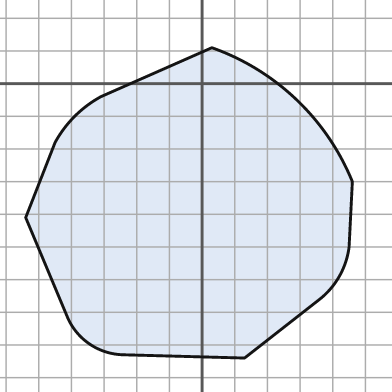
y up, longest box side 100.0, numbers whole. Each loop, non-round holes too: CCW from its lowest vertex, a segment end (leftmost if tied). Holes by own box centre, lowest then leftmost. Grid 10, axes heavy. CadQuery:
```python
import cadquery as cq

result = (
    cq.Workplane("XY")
    .moveTo(13.0, -84.0)
    .lineTo(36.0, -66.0)
    .threePointArc((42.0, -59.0), (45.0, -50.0))
    .lineTo(46.0, -30.0)
    .threePointArc((29.0, -5.0), (3.0, 11.0))
    .lineTo(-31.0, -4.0)
    .threePointArc((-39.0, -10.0), (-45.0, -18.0))
    .lineTo(-54.0, -41.0)
    .lineTo(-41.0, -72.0)
    .threePointArc((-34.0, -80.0), (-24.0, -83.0))
    .close()
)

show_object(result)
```